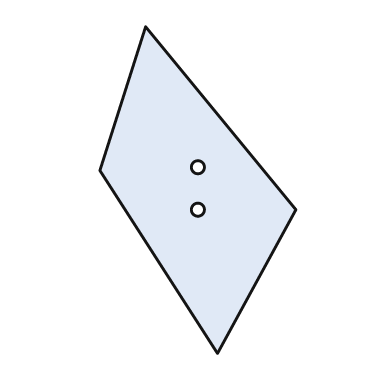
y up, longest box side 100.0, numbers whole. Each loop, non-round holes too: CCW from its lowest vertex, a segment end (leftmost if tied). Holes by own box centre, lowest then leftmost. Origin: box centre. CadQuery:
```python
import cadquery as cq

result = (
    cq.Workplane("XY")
    .moveTo(6.0, -50.0)
    .lineTo(30.0, -6.0)
    .lineTo(-16.0, 50.0)
    .lineTo(-30.0, 6.0)
    .close()
    .moveTo(0.0, -6.0)
    .circle(2.0)
    .moveTo(0.0, 7.0)
    .circle(2.0)
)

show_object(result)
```